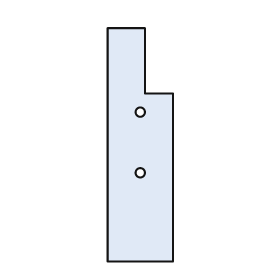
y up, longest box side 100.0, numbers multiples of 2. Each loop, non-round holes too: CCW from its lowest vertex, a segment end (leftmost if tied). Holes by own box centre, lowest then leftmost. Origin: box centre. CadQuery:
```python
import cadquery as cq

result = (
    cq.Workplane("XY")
    .moveTo(-14.0, -50.0)
    .lineTo(14.0, -50.0)
    .lineTo(14.0, 22.0)
    .lineTo(2.0, 22.0)
    .lineTo(2.0, 50.0)
    .lineTo(-14.0, 50.0)
    .close()
    .moveTo(0.0, -12.0)
    .circle(2.0)
    .moveTo(0.0, 14.0)
    .circle(2.0)
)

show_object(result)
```